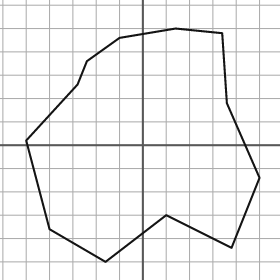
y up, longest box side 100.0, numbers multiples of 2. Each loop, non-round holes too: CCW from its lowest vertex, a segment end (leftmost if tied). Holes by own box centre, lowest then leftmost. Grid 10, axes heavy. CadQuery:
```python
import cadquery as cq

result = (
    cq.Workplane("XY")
    .moveTo(-16.0, -50.0)
    .lineTo(10.0, -30.0)
    .lineTo(38.0, -44.0)
    .lineTo(50.0, -14.0)
    .lineTo(36.0, 18.0)
    .lineTo(34.0, 48.0)
    .lineTo(14.0, 50.0)
    .lineTo(-10.0, 46.0)
    .lineTo(-24.0, 36.0)
    .lineTo(-28.0, 26.0)
    .lineTo(-50.0, 2.0)
    .lineTo(-40.0, -36.0)
    .close()
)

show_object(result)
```